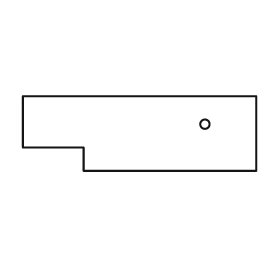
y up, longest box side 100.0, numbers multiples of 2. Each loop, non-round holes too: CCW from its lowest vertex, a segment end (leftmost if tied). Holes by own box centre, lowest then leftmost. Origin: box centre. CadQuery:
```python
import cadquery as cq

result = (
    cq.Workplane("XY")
    .moveTo(-24.0, -16.0)
    .lineTo(50.0, -16.0)
    .lineTo(50.0, 16.0)
    .lineTo(-50.0, 16.0)
    .lineTo(-50.0, -6.0)
    .lineTo(-24.0, -6.0)
    .close()
    .moveTo(28.0, 4.0)
    .circle(2.0)
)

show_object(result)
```